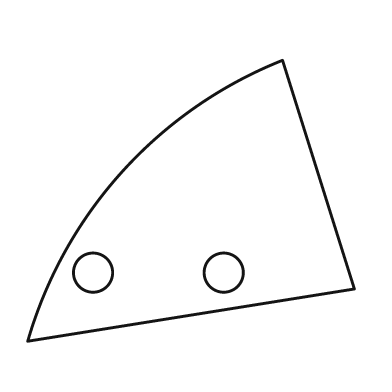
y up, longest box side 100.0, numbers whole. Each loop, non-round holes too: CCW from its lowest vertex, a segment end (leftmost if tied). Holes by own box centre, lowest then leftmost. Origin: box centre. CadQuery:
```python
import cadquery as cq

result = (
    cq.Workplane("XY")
    .moveTo(-50.0, -43.0)
    .lineTo(50.0, -27.0)
    .lineTo(28.0, 43.0)
    .threePointArc((-21.0, 9.0), (-50.0, -43.0))
    .close()
    .moveTo(-30.0, -22.0)
    .circle(6.0)
    .moveTo(10.0, -22.0)
    .circle(6.0)
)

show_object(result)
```